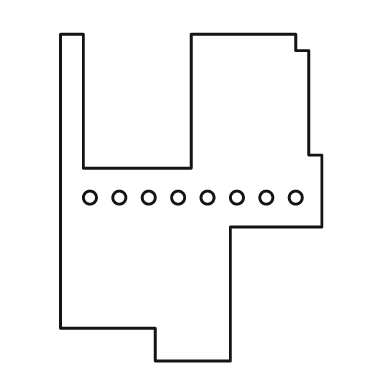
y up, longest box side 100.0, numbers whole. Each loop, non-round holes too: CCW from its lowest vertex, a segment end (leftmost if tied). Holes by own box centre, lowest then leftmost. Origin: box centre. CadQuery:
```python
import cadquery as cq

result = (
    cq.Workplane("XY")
    .moveTo(-11.0, -50.0)
    .lineTo(12.0, -50.0)
    .lineTo(12.0, -9.0)
    .lineTo(40.0, -9.0)
    .lineTo(40.0, 13.0)
    .lineTo(36.0, 13.0)
    .lineTo(36.0, 45.0)
    .lineTo(32.0, 45.0)
    .lineTo(32.0, 50.0)
    .lineTo(0.0, 50.0)
    .lineTo(0.0, 9.0)
    .lineTo(-33.0, 9.0)
    .lineTo(-33.0, 50.0)
    .lineTo(-40.0, 50.0)
    .lineTo(-40.0, -40.0)
    .lineTo(-11.0, -40.0)
    .close()
    .moveTo(-31.0, 0.0)
    .circle(2.0)
    .moveTo(-22.0, 0.0)
    .circle(2.0)
    .moveTo(-13.0, 0.0)
    .circle(2.0)
    .moveTo(-4.0, 0.0)
    .circle(2.0)
    .moveTo(5.0, 0.0)
    .circle(2.0)
    .moveTo(14.0, 0.0)
    .circle(2.0)
    .moveTo(23.0, 0.0)
    .circle(2.0)
    .moveTo(32.0, 0.0)
    .circle(2.0)
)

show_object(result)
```